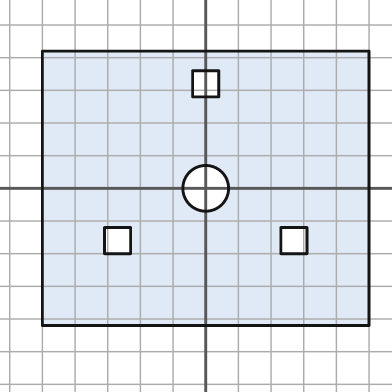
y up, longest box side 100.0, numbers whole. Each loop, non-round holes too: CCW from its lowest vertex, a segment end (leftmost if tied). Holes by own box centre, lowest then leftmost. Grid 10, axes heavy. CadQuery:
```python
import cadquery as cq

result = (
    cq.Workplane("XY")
    .moveTo(-50.0, -42.0)
    .lineTo(50.0, -42.0)
    .lineTo(50.0, 42.0)
    .lineTo(-50.0, 42.0)
    .close()
    .moveTo(-31.0, -20.0)
    .lineTo(-23.0, -20.0)
    .lineTo(-23.0, -12.0)
    .lineTo(-31.0, -12.0)
    .close()
    .moveTo(23.0, -20.0)
    .lineTo(31.0, -20.0)
    .lineTo(31.0, -12.0)
    .lineTo(23.0, -12.0)
    .close()
    .moveTo(0.0, 0.0)
    .circle(7.0)
    .moveTo(-4.0, 28.0)
    .lineTo(4.0, 28.0)
    .lineTo(4.0, 36.0)
    .lineTo(-4.0, 36.0)
    .close()
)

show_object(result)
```